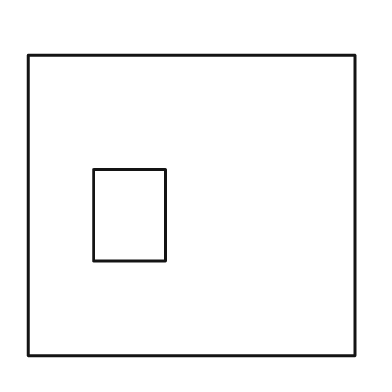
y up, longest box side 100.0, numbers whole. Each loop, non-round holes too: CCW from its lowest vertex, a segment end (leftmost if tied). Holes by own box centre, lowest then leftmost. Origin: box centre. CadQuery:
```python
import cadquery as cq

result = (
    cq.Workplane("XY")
    .moveTo(-50.0, -46.0)
    .lineTo(50.0, -46.0)
    .lineTo(50.0, 46.0)
    .lineTo(-50.0, 46.0)
    .close()
    .moveTo(-30.0, -17.0)
    .lineTo(-8.0, -17.0)
    .lineTo(-8.0, 11.0)
    .lineTo(-30.0, 11.0)
    .close()
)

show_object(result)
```